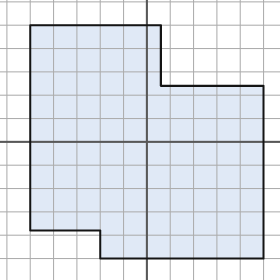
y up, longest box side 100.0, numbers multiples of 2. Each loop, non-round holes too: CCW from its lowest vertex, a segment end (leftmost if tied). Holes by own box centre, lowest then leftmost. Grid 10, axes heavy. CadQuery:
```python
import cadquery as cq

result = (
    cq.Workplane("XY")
    .moveTo(-20.0, -50.0)
    .lineTo(50.0, -50.0)
    .lineTo(50.0, 24.0)
    .lineTo(6.0, 24.0)
    .lineTo(6.0, 50.0)
    .lineTo(-50.0, 50.0)
    .lineTo(-50.0, -38.0)
    .lineTo(-20.0, -38.0)
    .close()
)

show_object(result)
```